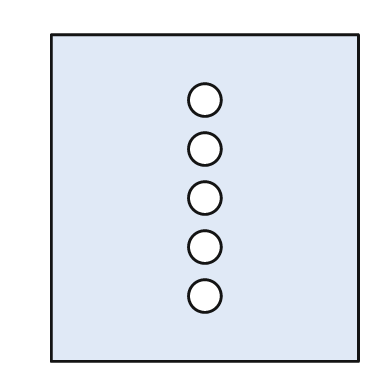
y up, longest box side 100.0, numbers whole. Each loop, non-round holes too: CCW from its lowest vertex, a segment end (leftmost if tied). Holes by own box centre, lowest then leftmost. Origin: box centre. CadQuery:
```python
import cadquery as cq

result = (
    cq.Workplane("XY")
    .moveTo(-47.0, -50.0)
    .lineTo(47.0, -50.0)
    .lineTo(47.0, 50.0)
    .lineTo(-47.0, 50.0)
    .close()
    .moveTo(0.0, -30.0)
    .circle(5.0)
    .moveTo(0.0, -15.0)
    .circle(5.0)
    .moveTo(0.0, 0.0)
    .circle(5.0)
    .moveTo(0.0, 15.0)
    .circle(5.0)
    .moveTo(0.0, 30.0)
    .circle(5.0)
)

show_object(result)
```